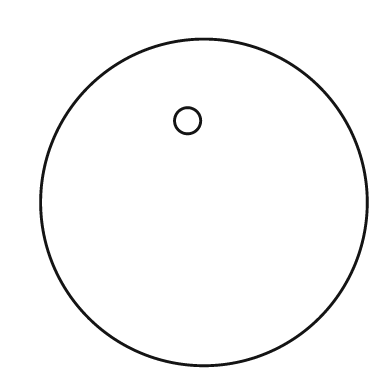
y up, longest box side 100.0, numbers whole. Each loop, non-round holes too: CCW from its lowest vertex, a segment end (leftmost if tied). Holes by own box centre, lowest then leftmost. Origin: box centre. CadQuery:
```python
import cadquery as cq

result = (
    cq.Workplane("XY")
    .moveTo(0.0, 0.0)
    .circle(50.0)
    .moveTo(-5.0, 25.0)
    .circle(4.0)
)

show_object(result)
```